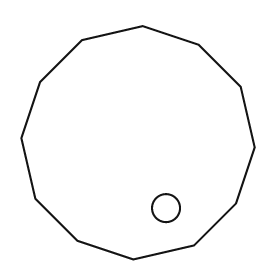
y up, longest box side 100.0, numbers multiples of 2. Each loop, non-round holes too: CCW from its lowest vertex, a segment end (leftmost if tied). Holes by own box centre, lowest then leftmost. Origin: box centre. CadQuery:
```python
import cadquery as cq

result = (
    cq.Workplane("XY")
    .moveTo(-2.0, -50.0)
    .lineTo(24.0, -44.0)
    .lineTo(42.0, -26.0)
    .lineTo(50.0, -2.0)
    .lineTo(44.0, 24.0)
    .lineTo(26.0, 42.0)
    .lineTo(2.0, 50.0)
    .lineTo(-24.0, 44.0)
    .lineTo(-42.0, 26.0)
    .lineTo(-50.0, 2.0)
    .lineTo(-44.0, -24.0)
    .lineTo(-26.0, -42.0)
    .close()
    .moveTo(12.0, -28.0)
    .circle(6.0)
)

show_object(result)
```